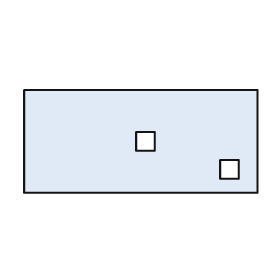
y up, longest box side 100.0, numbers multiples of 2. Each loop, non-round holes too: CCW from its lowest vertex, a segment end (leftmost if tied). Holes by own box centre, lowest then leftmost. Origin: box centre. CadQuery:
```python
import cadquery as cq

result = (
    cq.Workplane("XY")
    .moveTo(-50.0, -22.0)
    .lineTo(50.0, -22.0)
    .lineTo(50.0, 22.0)
    .lineTo(-50.0, 22.0)
    .close()
    .moveTo(34.0, -16.0)
    .lineTo(42.0, -16.0)
    .lineTo(42.0, -8.0)
    .lineTo(34.0, -8.0)
    .close()
    .moveTo(-2.0, -4.0)
    .lineTo(6.0, -4.0)
    .lineTo(6.0, 4.0)
    .lineTo(-2.0, 4.0)
    .close()
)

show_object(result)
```